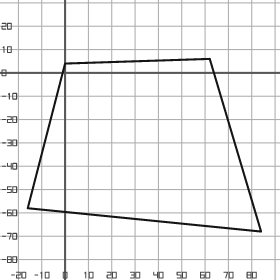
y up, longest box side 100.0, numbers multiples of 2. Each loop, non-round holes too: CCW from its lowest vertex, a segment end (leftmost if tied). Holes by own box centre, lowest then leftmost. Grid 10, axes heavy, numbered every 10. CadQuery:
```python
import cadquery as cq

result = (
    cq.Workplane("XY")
    .moveTo(84.0, -68.0)
    .lineTo(62.0, 6.0)
    .lineTo(0.0, 4.0)
    .lineTo(-16.0, -58.0)
    .close()
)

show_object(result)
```